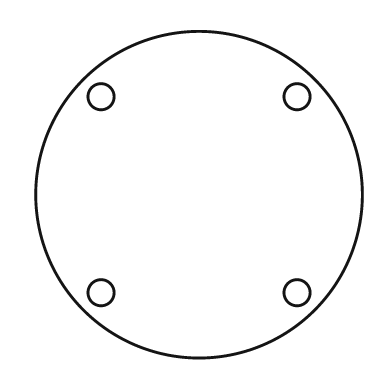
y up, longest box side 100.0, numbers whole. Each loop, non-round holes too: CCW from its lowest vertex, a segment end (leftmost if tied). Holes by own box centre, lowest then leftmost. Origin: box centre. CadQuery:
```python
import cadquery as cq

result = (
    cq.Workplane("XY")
    .moveTo(0.0, 0.0)
    .circle(50.0)
    .moveTo(-30.0, -30.0)
    .circle(4.0)
    .moveTo(30.0, -30.0)
    .circle(4.0)
    .moveTo(-30.0, 30.0)
    .circle(4.0)
    .moveTo(30.0, 30.0)
    .circle(4.0)
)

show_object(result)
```